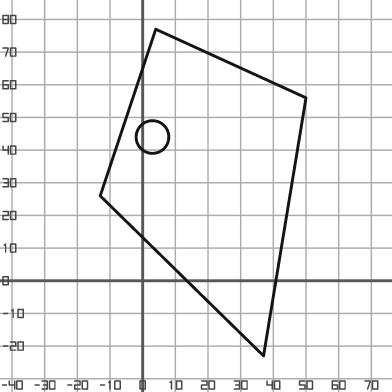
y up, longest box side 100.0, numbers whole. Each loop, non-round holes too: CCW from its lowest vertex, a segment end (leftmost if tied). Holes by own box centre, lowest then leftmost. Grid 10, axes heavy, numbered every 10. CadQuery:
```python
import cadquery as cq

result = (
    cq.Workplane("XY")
    .moveTo(37.0, -23.0)
    .lineTo(50.0, 56.0)
    .lineTo(4.0, 77.0)
    .lineTo(-13.0, 26.0)
    .close()
    .moveTo(3.0, 44.0)
    .circle(5.0)
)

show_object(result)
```